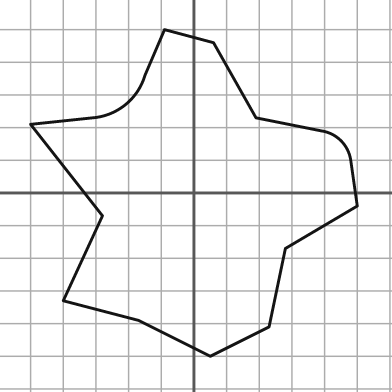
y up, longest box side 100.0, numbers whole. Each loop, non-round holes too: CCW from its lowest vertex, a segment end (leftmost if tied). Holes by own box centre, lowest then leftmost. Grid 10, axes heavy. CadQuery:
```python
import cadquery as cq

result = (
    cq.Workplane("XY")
    .moveTo(5.0, -50.0)
    .lineTo(23.0, -41.0)
    .lineTo(28.0, -17.0)
    .lineTo(50.0, -4.0)
    .lineTo(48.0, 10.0)
    .threePointArc((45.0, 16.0), (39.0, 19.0))
    .lineTo(19.0, 23.0)
    .lineTo(6.0, 46.0)
    .lineTo(-9.0, 50.0)
    .lineTo(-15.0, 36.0)
    .threePointArc((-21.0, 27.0), (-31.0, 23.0))
    .lineTo(-50.0, 21.0)
    .lineTo(-28.0, -7.0)
    .lineTo(-40.0, -33.0)
    .lineTo(-17.0, -39.0)
    .close()
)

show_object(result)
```